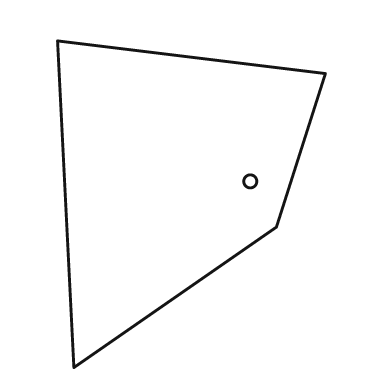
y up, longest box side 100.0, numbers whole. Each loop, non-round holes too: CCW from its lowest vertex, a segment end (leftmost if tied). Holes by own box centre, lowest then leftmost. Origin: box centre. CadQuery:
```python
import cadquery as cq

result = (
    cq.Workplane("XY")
    .moveTo(-36.0, -50.0)
    .lineTo(26.0, -7.0)
    .lineTo(41.0, 40.0)
    .lineTo(-41.0, 50.0)
    .close()
    .moveTo(18.0, 7.0)
    .circle(2.0)
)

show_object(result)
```